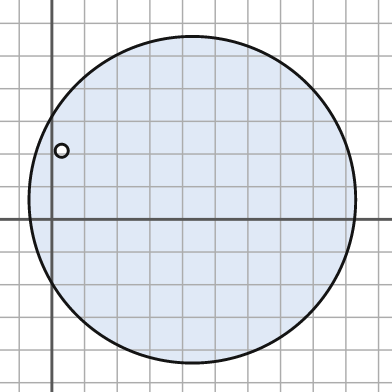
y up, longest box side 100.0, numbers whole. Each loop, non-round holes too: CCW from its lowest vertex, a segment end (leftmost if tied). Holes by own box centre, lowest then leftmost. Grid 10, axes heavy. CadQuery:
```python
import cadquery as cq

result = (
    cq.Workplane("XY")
    .moveTo(43.0, 6.0)
    .circle(50.0)
    .moveTo(3.0, 21.0)
    .circle(2.0)
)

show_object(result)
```